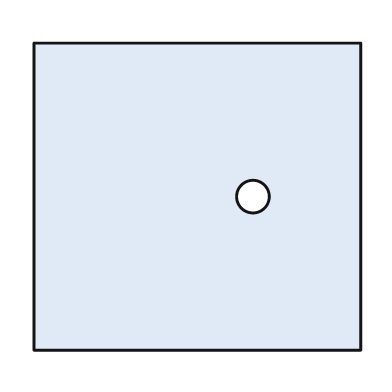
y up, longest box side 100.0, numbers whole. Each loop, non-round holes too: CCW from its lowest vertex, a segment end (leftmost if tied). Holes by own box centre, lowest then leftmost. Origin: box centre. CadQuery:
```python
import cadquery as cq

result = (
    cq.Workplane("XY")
    .moveTo(-50.0, -47.0)
    .lineTo(50.0, -47.0)
    .lineTo(50.0, 47.0)
    .lineTo(-50.0, 47.0)
    .close()
    .moveTo(17.0, 0.0)
    .circle(5.0)
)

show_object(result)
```